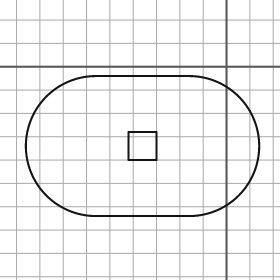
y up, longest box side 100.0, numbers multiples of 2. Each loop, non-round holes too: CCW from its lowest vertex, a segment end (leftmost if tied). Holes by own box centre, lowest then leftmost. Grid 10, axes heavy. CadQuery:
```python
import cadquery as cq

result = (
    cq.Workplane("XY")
    .moveTo(-56.0, -64.0)
    .lineTo(-16.0, -64.0)
    .threePointArc((14.0, -34.0), (-16.0, -4.0))
    .lineTo(-56.0, -4.0)
    .threePointArc((-86.0, -34.0), (-56.0, -64.0))
    .close()
    .moveTo(-42.0, -40.0)
    .lineTo(-30.0, -40.0)
    .lineTo(-30.0, -28.0)
    .lineTo(-42.0, -28.0)
    .close()
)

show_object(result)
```